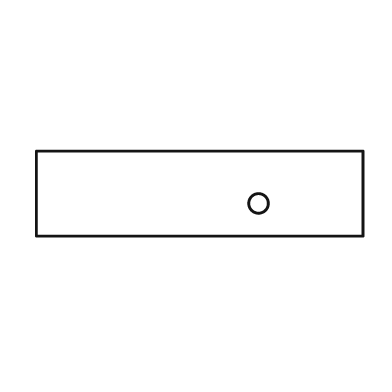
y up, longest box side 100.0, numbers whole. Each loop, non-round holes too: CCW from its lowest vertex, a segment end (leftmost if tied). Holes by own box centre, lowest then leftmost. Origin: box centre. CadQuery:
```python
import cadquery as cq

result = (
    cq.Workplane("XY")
    .moveTo(-50.0, -13.0)
    .lineTo(50.0, -13.0)
    .lineTo(50.0, 13.0)
    .lineTo(-50.0, 13.0)
    .close()
    .moveTo(18.0, -3.0)
    .circle(3.0)
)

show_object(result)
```